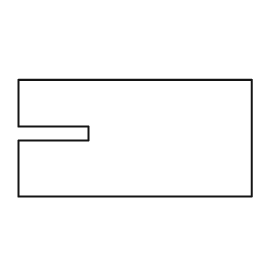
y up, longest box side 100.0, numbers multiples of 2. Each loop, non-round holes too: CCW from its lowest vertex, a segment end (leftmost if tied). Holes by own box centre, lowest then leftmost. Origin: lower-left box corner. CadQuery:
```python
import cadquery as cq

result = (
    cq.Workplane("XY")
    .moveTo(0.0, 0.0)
    .lineTo(100.0, 0.0)
    .lineTo(100.0, 50.0)
    .lineTo(0.0, 50.0)
    .lineTo(0.0, 30.0)
    .lineTo(30.0, 30.0)
    .lineTo(30.0, 24.0)
    .lineTo(0.0, 24.0)
    .close()
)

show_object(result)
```